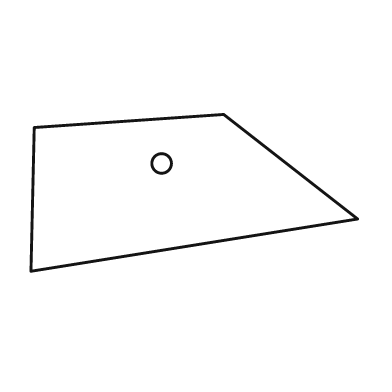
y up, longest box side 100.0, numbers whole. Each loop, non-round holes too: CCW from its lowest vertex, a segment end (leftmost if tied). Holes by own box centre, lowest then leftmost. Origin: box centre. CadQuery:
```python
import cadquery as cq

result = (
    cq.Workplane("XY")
    .moveTo(-50.0, -24.0)
    .lineTo(50.0, -8.0)
    .lineTo(9.0, 24.0)
    .lineTo(-49.0, 20.0)
    .close()
    .moveTo(-10.0, 9.0)
    .circle(3.0)
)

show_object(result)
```